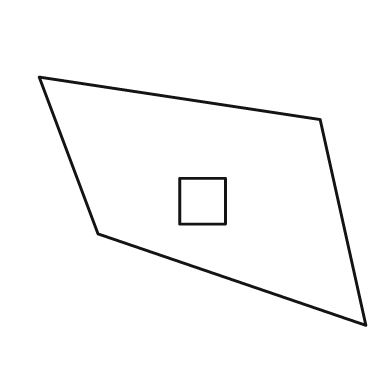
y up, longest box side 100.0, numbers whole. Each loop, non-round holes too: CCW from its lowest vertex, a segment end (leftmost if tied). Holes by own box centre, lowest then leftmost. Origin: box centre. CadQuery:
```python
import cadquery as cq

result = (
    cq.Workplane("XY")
    .moveTo(50.0, -38.0)
    .lineTo(36.0, 25.0)
    .lineTo(-50.0, 38.0)
    .lineTo(-32.0, -10.0)
    .close()
    .moveTo(-7.0, -7.0)
    .lineTo(7.0, -7.0)
    .lineTo(7.0, 7.0)
    .lineTo(-7.0, 7.0)
    .close()
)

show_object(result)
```